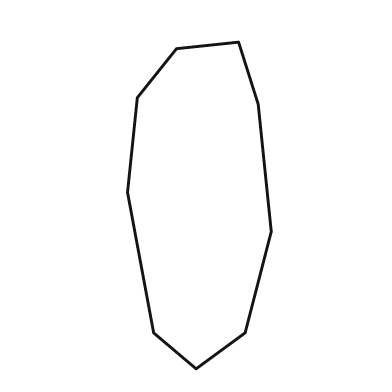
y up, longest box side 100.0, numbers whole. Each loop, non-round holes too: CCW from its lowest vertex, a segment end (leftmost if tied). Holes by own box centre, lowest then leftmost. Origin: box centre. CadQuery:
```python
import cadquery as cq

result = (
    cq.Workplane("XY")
    .moveTo(-1.0, -50.0)
    .lineTo(14.0, -39.0)
    .lineTo(22.0, -8.0)
    .lineTo(18.0, 31.0)
    .lineTo(12.0, 50.0)
    .lineTo(-7.0, 48.0)
    .lineTo(-19.0, 33.0)
    .lineTo(-22.0, 4.0)
    .lineTo(-14.0, -39.0)
    .close()
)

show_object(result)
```